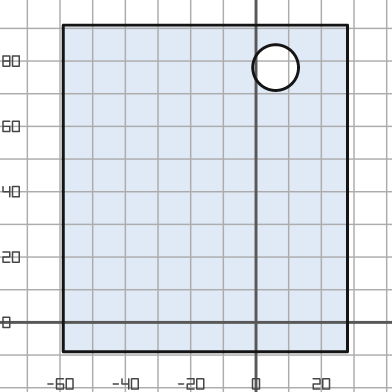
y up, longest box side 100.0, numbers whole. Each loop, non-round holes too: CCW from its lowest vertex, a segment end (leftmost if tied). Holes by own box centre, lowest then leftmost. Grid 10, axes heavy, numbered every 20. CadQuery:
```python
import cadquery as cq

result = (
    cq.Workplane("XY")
    .moveTo(-59.0, -9.0)
    .lineTo(28.0, -9.0)
    .lineTo(28.0, 91.0)
    .lineTo(-59.0, 91.0)
    .close()
    .moveTo(6.0, 78.0)
    .circle(7.0)
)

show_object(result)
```